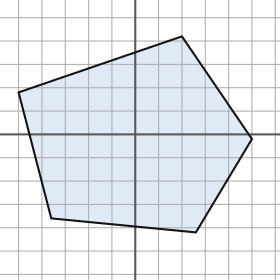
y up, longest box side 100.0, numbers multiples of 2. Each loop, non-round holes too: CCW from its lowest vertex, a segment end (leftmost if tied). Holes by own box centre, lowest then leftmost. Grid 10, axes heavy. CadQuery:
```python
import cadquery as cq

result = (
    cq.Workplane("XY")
    .moveTo(26.0, -42.0)
    .lineTo(50.0, -2.0)
    .lineTo(20.0, 42.0)
    .lineTo(-50.0, 18.0)
    .lineTo(-36.0, -36.0)
    .close()
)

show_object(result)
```